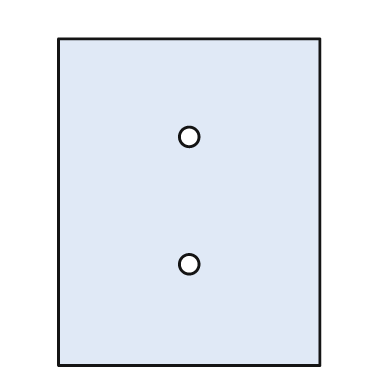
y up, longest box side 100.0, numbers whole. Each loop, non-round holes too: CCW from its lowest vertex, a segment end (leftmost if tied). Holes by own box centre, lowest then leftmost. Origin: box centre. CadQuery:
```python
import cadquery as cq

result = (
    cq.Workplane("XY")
    .moveTo(-40.0, -50.0)
    .lineTo(40.0, -50.0)
    .lineTo(40.0, 50.0)
    .lineTo(-40.0, 50.0)
    .close()
    .moveTo(0.0, -19.0)
    .circle(3.0)
    .moveTo(0.0, 20.0)
    .circle(3.0)
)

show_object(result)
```